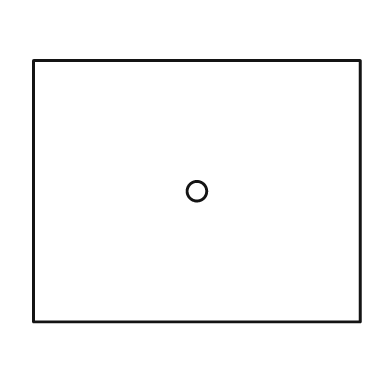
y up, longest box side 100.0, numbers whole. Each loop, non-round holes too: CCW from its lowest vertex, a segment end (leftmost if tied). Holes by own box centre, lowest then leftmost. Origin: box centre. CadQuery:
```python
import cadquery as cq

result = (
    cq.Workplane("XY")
    .moveTo(-50.0, -40.0)
    .lineTo(50.0, -40.0)
    .lineTo(50.0, 40.0)
    .lineTo(-50.0, 40.0)
    .close()
    .moveTo(0.0, 0.0)
    .circle(3.0)
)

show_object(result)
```